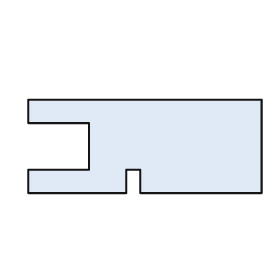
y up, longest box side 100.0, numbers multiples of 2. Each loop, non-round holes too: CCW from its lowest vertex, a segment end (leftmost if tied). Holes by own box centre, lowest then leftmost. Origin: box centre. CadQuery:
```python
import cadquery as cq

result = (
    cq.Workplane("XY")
    .moveTo(-50.0, -20.0)
    .lineTo(-8.0, -20.0)
    .lineTo(-8.0, -10.0)
    .lineTo(-2.0, -10.0)
    .lineTo(-2.0, -20.0)
    .lineTo(50.0, -20.0)
    .lineTo(50.0, 20.0)
    .lineTo(-50.0, 20.0)
    .lineTo(-50.0, 10.0)
    .lineTo(-24.0, 10.0)
    .lineTo(-24.0, -10.0)
    .lineTo(-50.0, -10.0)
    .close()
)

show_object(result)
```